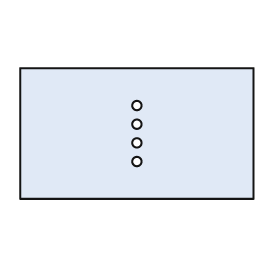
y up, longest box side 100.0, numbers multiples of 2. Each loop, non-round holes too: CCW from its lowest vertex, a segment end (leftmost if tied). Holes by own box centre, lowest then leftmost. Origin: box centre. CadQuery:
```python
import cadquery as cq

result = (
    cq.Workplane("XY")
    .moveTo(-50.0, -28.0)
    .lineTo(50.0, -28.0)
    .lineTo(50.0, 28.0)
    .lineTo(-50.0, 28.0)
    .close()
    .moveTo(0.0, -12.0)
    .circle(2.0)
    .moveTo(0.0, -4.0)
    .circle(2.0)
    .moveTo(0.0, 4.0)
    .circle(2.0)
    .moveTo(0.0, 12.0)
    .circle(2.0)
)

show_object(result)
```